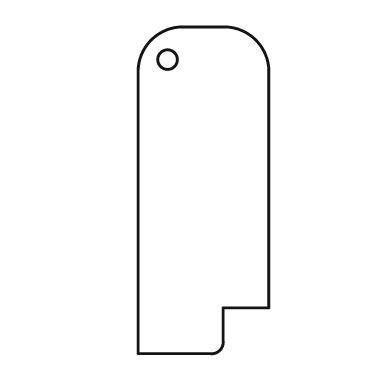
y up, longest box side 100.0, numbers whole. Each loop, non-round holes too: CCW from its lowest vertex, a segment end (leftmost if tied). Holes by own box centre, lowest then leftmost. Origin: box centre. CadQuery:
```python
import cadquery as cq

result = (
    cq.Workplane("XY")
    .moveTo(-20.0, -50.0)
    .lineTo(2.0, -50.0)
    .threePointArc((5.0, -49.0), (6.0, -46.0))
    .lineTo(6.0, -36.0)
    .lineTo(20.0, -36.0)
    .lineTo(20.0, 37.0)
    .threePointArc((16.0, 46.0), (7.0, 50.0))
    .lineTo(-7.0, 50.0)
    .threePointArc((-16.0, 46.0), (-20.0, 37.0))
    .close()
    .moveTo(-11.0, 40.0)
    .circle(3.0)
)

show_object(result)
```